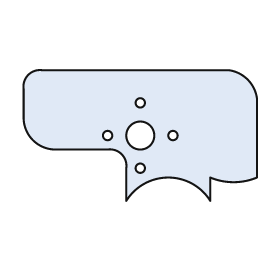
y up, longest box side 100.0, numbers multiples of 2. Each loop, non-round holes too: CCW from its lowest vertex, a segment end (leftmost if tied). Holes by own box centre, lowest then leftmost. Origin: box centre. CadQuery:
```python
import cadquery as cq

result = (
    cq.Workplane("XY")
    .moveTo(-6.0, -28.0)
    .threePointArc((12.0, -18.0), (30.0, -28.0))
    .lineTo(30.0, -18.0)
    .threePointArc((40.0, -20.0), (50.0, -18.0))
    .lineTo(50.0, 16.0)
    .threePointArc((46.0, 24.0), (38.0, 28.0))
    .lineTo(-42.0, 28.0)
    .threePointArc((-48.0, 26.0), (-50.0, 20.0))
    .lineTo(-50.0, 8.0)
    .threePointArc((-46.0, -2.0), (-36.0, -6.0))
    .lineTo(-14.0, -6.0)
    .threePointArc((-8.0, -8.0), (-6.0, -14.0))
    .close()
    .moveTo(0.0, -14.0)
    .circle(2.0)
    .moveTo(-14.0, 0.0)
    .circle(2.0)
    .moveTo(0.0, 0.0)
    .circle(6.0)
    .moveTo(14.0, 0.0)
    .circle(2.0)
    .moveTo(0.0, 14.0)
    .circle(2.0)
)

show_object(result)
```